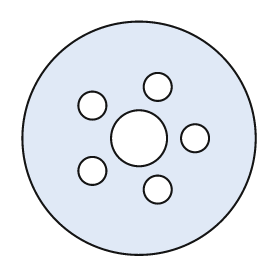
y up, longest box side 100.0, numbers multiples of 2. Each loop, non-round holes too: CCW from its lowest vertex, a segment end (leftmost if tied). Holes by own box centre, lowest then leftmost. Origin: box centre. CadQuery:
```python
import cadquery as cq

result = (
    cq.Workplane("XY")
    .moveTo(0.0, 0.0)
    .circle(50.0)
    .moveTo(8.0, -22.0)
    .circle(6.0)
    .moveTo(-20.0, -14.0)
    .circle(6.0)
    .moveTo(0.0, 0.0)
    .circle(12.0)
    .moveTo(24.0, 0.0)
    .circle(6.0)
    .moveTo(-20.0, 14.0)
    .circle(6.0)
    .moveTo(8.0, 22.0)
    .circle(6.0)
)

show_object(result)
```